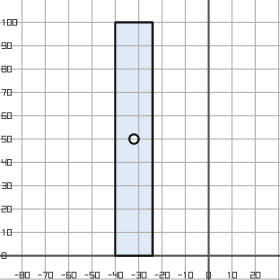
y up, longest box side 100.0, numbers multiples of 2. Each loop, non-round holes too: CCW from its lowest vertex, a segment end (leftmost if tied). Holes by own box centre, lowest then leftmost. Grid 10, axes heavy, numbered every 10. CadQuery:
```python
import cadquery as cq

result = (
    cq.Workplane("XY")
    .moveTo(-40.0, 0.0)
    .lineTo(-24.0, 0.0)
    .lineTo(-24.0, 100.0)
    .lineTo(-40.0, 100.0)
    .close()
    .moveTo(-32.0, 50.0)
    .circle(2.0)
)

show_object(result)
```